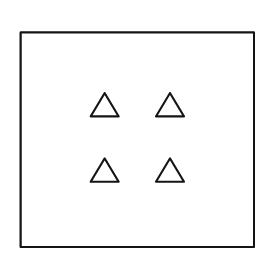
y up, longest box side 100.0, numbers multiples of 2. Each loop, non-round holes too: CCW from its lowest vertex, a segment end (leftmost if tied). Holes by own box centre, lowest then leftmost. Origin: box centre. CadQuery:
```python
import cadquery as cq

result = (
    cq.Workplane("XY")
    .moveTo(-50.0, -46.0)
    .lineTo(50.0, -46.0)
    .lineTo(50.0, 46.0)
    .lineTo(-50.0, 46.0)
    .close()
    .moveTo(-20.0, -18.0)
    .lineTo(-8.0, -18.0)
    .lineTo(-14.0, -8.0)
    .close()
    .moveTo(8.0, -18.0)
    .lineTo(20.0, -18.0)
    .lineTo(14.0, -8.0)
    .close()
    .moveTo(-20.0, 10.0)
    .lineTo(-8.0, 10.0)
    .lineTo(-14.0, 20.0)
    .close()
    .moveTo(8.0, 10.0)
    .lineTo(20.0, 10.0)
    .lineTo(14.0, 20.0)
    .close()
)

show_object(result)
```